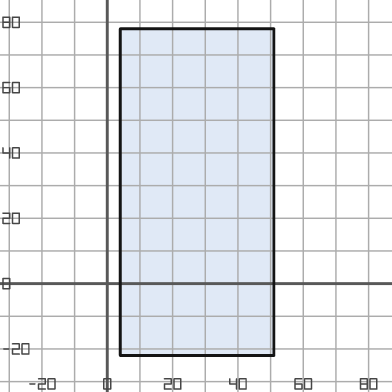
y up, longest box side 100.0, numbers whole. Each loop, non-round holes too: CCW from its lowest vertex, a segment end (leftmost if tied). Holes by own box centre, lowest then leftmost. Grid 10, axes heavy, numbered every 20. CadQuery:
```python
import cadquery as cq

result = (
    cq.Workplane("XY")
    .moveTo(4.0, -22.0)
    .lineTo(51.0, -22.0)
    .lineTo(51.0, 78.0)
    .lineTo(4.0, 78.0)
    .close()
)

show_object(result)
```